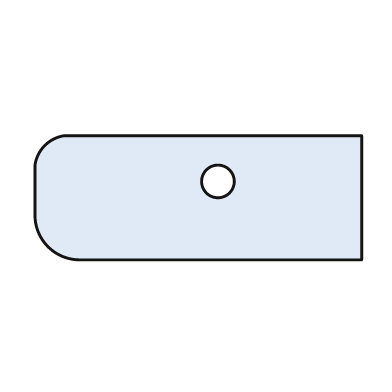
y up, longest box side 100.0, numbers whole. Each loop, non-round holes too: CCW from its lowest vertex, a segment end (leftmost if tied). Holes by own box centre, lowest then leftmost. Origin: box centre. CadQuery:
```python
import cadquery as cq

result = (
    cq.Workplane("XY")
    .moveTo(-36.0, -19.0)
    .lineTo(50.0, -19.0)
    .lineTo(50.0, 19.0)
    .lineTo(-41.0, 19.0)
    .threePointArc((-47.0, 16.0), (-50.0, 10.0))
    .lineTo(-50.0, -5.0)
    .threePointArc((-46.0, -15.0), (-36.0, -19.0))
    .close()
    .moveTo(6.0, 5.0)
    .circle(5.0)
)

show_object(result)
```